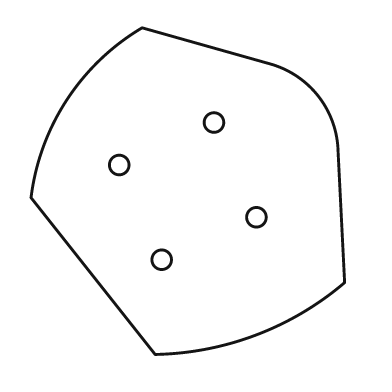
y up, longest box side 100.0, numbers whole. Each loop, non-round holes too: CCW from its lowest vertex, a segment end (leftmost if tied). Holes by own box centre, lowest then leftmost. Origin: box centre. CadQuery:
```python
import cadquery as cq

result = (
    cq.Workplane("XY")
    .moveTo(-10.0, -50.0)
    .threePointArc((21.0, -44.0), (48.0, -28.0))
    .lineTo(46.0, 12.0)
    .threePointArc((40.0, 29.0), (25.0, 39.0))
    .lineTo(-14.0, 50.0)
    .threePointArc((-37.0, 28.0), (-48.0, -2.0))
    .close()
    .moveTo(-8.0, -21.0)
    .circle(3.0)
    .moveTo(21.0, -8.0)
    .circle(3.0)
    .moveTo(-21.0, 8.0)
    .circle(3.0)
    .moveTo(8.0, 21.0)
    .circle(3.0)
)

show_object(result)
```